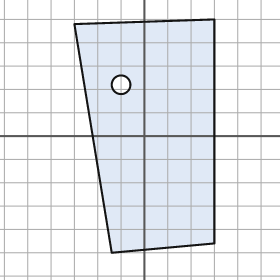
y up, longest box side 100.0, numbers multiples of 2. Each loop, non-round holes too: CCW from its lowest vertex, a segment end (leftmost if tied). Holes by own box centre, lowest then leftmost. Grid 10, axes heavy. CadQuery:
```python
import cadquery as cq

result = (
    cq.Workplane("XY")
    .moveTo(-14.0, -50.0)
    .lineTo(30.0, -46.0)
    .lineTo(30.0, 50.0)
    .lineTo(-30.0, 48.0)
    .close()
    .moveTo(-10.0, 22.0)
    .circle(4.0)
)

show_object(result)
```